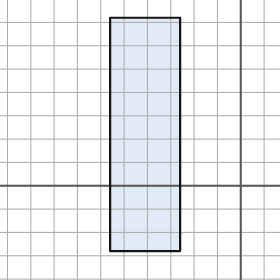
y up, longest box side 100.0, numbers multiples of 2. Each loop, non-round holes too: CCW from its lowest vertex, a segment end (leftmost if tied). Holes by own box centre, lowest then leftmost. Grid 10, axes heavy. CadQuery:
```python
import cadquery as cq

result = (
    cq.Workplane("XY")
    .moveTo(-56.0, -28.0)
    .lineTo(-26.0, -28.0)
    .lineTo(-26.0, 72.0)
    .lineTo(-56.0, 72.0)
    .close()
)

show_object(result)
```